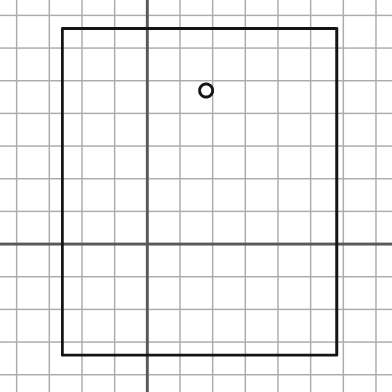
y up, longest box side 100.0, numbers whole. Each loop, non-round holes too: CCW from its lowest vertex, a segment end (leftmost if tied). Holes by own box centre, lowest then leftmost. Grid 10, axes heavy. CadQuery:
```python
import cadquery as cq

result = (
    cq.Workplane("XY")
    .moveTo(-26.0, -34.0)
    .lineTo(58.0, -34.0)
    .lineTo(58.0, 66.0)
    .lineTo(-26.0, 66.0)
    .close()
    .moveTo(18.0, 47.0)
    .circle(2.0)
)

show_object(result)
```